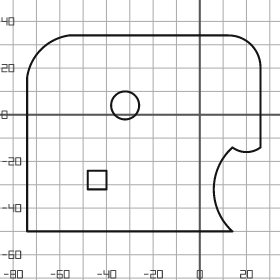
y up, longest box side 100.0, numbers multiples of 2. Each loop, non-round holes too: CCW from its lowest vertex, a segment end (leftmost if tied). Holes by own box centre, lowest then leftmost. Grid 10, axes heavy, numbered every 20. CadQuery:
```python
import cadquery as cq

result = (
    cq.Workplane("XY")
    .moveTo(-74.0, -50.0)
    .lineTo(14.0, -50.0)
    .threePointArc((6.0, -32.0), (14.0, -14.0))
    .threePointArc((20.0, -16.0), (26.0, -14.0))
    .lineTo(26.0, 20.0)
    .threePointArc((22.0, 30.0), (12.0, 34.0))
    .lineTo(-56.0, 34.0)
    .threePointArc((-68.0, 28.0), (-74.0, 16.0))
    .close()
    .moveTo(-48.0, -32.0)
    .lineTo(-40.0, -32.0)
    .lineTo(-40.0, -24.0)
    .lineTo(-48.0, -24.0)
    .close()
    .moveTo(-32.0, 4.0)
    .circle(6.0)
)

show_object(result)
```